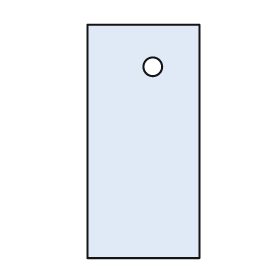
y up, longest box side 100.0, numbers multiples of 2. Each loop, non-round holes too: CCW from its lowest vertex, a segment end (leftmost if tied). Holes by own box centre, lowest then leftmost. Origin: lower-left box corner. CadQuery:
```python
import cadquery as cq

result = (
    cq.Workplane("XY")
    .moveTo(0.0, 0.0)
    .lineTo(48.0, 0.0)
    .lineTo(48.0, 100.0)
    .lineTo(0.0, 100.0)
    .close()
    .moveTo(28.0, 82.0)
    .circle(4.0)
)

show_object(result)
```